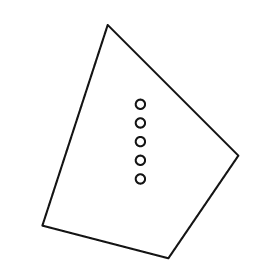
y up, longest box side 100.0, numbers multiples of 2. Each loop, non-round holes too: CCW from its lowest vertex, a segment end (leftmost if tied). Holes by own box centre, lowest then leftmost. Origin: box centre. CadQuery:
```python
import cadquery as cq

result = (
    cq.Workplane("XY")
    .moveTo(12.0, -50.0)
    .lineTo(42.0, -6.0)
    .lineTo(-14.0, 50.0)
    .lineTo(-42.0, -36.0)
    .close()
    .moveTo(0.0, -16.0)
    .circle(2.0)
    .moveTo(0.0, -8.0)
    .circle(2.0)
    .moveTo(0.0, 0.0)
    .circle(2.0)
    .moveTo(0.0, 8.0)
    .circle(2.0)
    .moveTo(0.0, 16.0)
    .circle(2.0)
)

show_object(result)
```